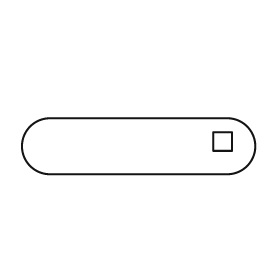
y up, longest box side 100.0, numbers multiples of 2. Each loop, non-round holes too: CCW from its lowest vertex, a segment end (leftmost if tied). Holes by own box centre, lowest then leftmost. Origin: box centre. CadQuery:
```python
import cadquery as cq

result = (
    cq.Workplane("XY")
    .moveTo(-38.0, -12.0)
    .lineTo(38.0, -12.0)
    .threePointArc((50.0, 0.0), (38.0, 12.0))
    .lineTo(-38.0, 12.0)
    .threePointArc((-50.0, 0.0), (-38.0, -12.0))
    .close()
    .moveTo(32.0, -2.0)
    .lineTo(40.0, -2.0)
    .lineTo(40.0, 6.0)
    .lineTo(32.0, 6.0)
    .close()
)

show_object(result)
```